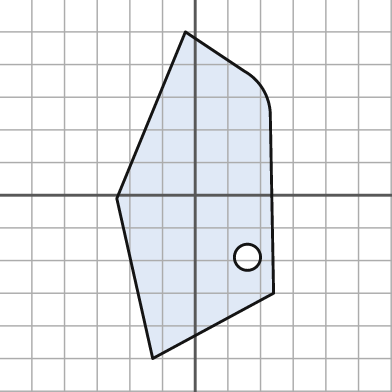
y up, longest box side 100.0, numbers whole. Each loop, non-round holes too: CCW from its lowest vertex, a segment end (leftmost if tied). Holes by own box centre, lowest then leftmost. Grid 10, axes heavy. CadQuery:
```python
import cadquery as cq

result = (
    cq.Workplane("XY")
    .moveTo(-13.0, -50.0)
    .lineTo(24.0, -30.0)
    .lineTo(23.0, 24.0)
    .threePointArc((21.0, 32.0), (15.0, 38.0))
    .lineTo(-3.0, 50.0)
    .lineTo(-24.0, -1.0)
    .close()
    .moveTo(16.0, -19.0)
    .circle(4.0)
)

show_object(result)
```